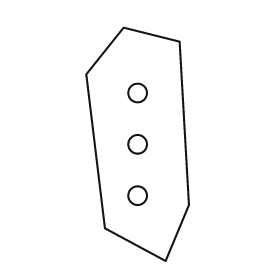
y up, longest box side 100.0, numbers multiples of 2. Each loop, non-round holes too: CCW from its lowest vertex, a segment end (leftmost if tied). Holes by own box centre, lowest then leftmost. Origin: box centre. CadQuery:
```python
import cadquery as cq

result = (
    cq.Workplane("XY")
    .moveTo(12.0, -50.0)
    .lineTo(22.0, -26.0)
    .lineTo(18.0, 44.0)
    .lineTo(-6.0, 50.0)
    .lineTo(-22.0, 30.0)
    .lineTo(-14.0, -36.0)
    .close()
    .moveTo(0.0, -22.0)
    .circle(4.0)
    .moveTo(0.0, 0.0)
    .circle(4.0)
    .moveTo(0.0, 22.0)
    .circle(4.0)
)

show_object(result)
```